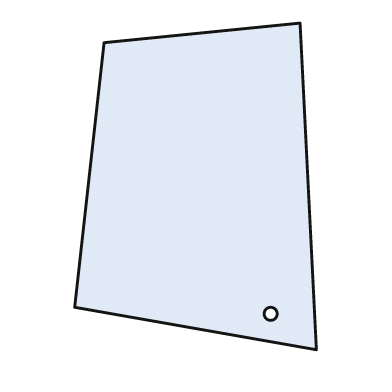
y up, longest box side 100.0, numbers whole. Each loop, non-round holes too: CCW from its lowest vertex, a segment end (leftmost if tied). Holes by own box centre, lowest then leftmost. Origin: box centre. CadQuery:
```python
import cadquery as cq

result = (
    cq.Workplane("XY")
    .moveTo(37.0, -50.0)
    .lineTo(32.0, 50.0)
    .lineTo(-28.0, 44.0)
    .lineTo(-37.0, -37.0)
    .close()
    .moveTo(23.0, -39.0)
    .circle(2.0)
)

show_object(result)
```